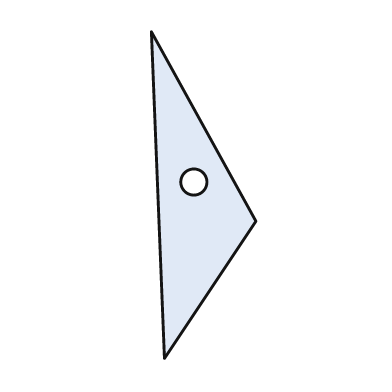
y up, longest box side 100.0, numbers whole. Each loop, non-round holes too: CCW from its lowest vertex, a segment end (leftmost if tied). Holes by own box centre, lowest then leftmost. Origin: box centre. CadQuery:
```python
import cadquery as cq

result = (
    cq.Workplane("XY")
    .moveTo(-12.0, -50.0)
    .lineTo(16.0, -8.0)
    .lineTo(-16.0, 50.0)
    .close()
    .moveTo(-3.0, 4.0)
    .circle(4.0)
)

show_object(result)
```